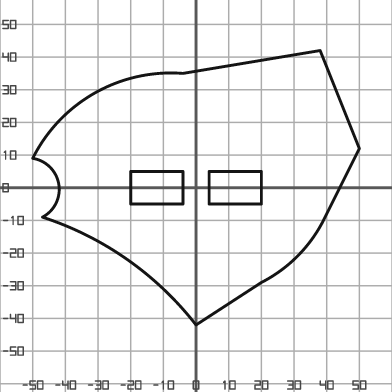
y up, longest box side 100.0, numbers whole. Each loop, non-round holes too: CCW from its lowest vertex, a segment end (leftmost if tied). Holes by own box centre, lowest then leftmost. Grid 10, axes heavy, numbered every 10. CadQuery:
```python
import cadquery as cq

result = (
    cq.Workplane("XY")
    .moveTo(0.0, -42.0)
    .lineTo(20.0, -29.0)
    .threePointArc((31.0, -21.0), (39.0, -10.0))
    .lineTo(50.0, 12.0)
    .lineTo(38.0, 42.0)
    .lineTo(-4.0, 35.0)
    .threePointArc((-31.0, 29.0), (-50.0, 9.0))
    .threePointArc((-42.0, 1.0), (-47.0, -9.0))
    .threePointArc((-21.0, -22.0), (0.0, -42.0))
    .close()
    .moveTo(-20.0, -5.0)
    .lineTo(-4.0, -5.0)
    .lineTo(-4.0, 5.0)
    .lineTo(-20.0, 5.0)
    .close()
    .moveTo(4.0, -5.0)
    .lineTo(20.0, -5.0)
    .lineTo(20.0, 5.0)
    .lineTo(4.0, 5.0)
    .close()
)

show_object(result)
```